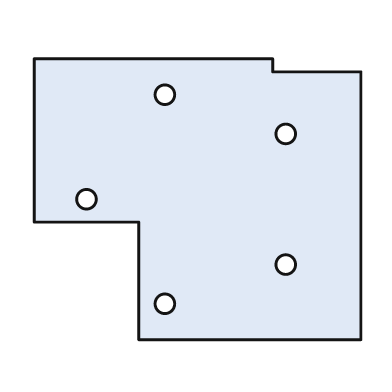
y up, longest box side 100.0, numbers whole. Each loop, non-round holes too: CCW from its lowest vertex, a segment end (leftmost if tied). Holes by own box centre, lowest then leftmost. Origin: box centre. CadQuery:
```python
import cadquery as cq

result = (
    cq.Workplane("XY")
    .moveTo(-18.0, -43.0)
    .lineTo(50.0, -43.0)
    .lineTo(50.0, 39.0)
    .lineTo(23.0, 39.0)
    .lineTo(23.0, 43.0)
    .lineTo(-50.0, 43.0)
    .lineTo(-50.0, -7.0)
    .lineTo(-18.0, -7.0)
    .close()
    .moveTo(-10.0, -32.0)
    .circle(3.0)
    .moveTo(27.0, -20.0)
    .circle(3.0)
    .moveTo(-34.0, 0.0)
    .circle(3.0)
    .moveTo(27.0, 20.0)
    .circle(3.0)
    .moveTo(-10.0, 32.0)
    .circle(3.0)
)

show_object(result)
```